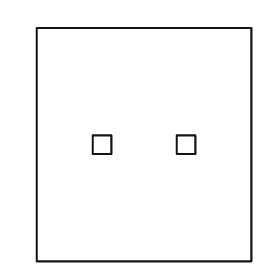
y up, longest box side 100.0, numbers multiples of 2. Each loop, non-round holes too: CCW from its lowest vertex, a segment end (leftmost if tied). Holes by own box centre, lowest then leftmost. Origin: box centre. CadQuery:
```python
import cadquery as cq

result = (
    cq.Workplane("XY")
    .moveTo(-46.0, -50.0)
    .lineTo(46.0, -50.0)
    .lineTo(46.0, 50.0)
    .lineTo(-46.0, 50.0)
    .close()
    .moveTo(-22.0, -4.0)
    .lineTo(-14.0, -4.0)
    .lineTo(-14.0, 4.0)
    .lineTo(-22.0, 4.0)
    .close()
    .moveTo(14.0, -4.0)
    .lineTo(22.0, -4.0)
    .lineTo(22.0, 4.0)
    .lineTo(14.0, 4.0)
    .close()
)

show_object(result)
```